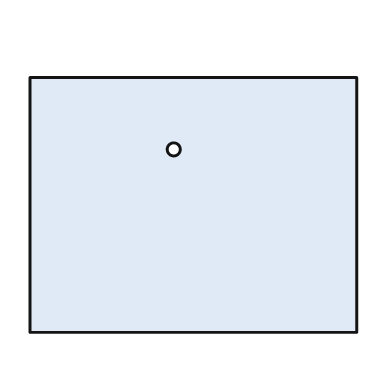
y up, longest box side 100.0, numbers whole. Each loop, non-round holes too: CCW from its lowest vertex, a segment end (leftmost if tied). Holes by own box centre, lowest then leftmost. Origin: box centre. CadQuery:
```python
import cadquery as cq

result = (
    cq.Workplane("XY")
    .moveTo(-50.0, -39.0)
    .lineTo(50.0, -39.0)
    .lineTo(50.0, 39.0)
    .lineTo(-50.0, 39.0)
    .close()
    .moveTo(-6.0, 17.0)
    .circle(2.0)
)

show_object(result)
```